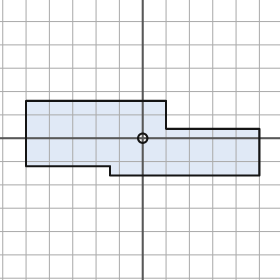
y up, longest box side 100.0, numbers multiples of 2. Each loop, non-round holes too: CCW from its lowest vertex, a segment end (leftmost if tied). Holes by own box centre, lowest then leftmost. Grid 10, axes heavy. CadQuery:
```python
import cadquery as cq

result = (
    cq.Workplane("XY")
    .moveTo(-14.0, -16.0)
    .lineTo(50.0, -16.0)
    .lineTo(50.0, 4.0)
    .lineTo(10.0, 4.0)
    .lineTo(10.0, 16.0)
    .lineTo(-50.0, 16.0)
    .lineTo(-50.0, -12.0)
    .lineTo(-14.0, -12.0)
    .close()
    .moveTo(0.0, 0.0)
    .circle(2.0)
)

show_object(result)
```